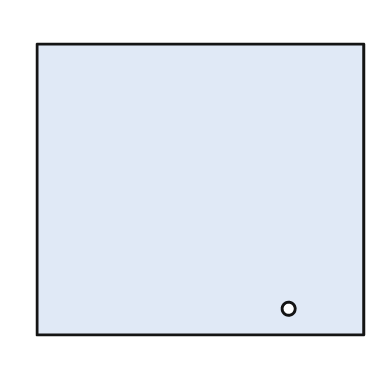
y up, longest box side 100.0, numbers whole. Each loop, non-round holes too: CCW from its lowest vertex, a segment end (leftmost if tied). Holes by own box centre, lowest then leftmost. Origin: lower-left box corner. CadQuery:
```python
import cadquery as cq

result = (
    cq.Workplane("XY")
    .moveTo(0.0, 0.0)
    .lineTo(100.0, 0.0)
    .lineTo(100.0, 89.0)
    .lineTo(0.0, 89.0)
    .close()
    .moveTo(77.0, 8.0)
    .circle(2.0)
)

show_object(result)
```